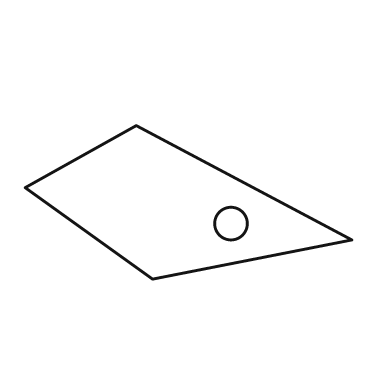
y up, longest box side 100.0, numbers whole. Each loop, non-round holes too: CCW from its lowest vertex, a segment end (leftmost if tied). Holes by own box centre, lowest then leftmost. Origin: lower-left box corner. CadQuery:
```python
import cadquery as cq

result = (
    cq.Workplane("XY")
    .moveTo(39.0, 0.0)
    .lineTo(100.0, 12.0)
    .lineTo(34.0, 47.0)
    .lineTo(0.0, 28.0)
    .close()
    .moveTo(63.0, 17.0)
    .circle(5.0)
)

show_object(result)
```